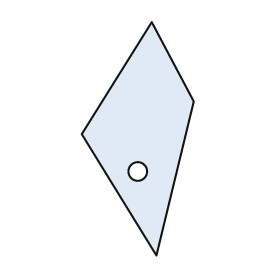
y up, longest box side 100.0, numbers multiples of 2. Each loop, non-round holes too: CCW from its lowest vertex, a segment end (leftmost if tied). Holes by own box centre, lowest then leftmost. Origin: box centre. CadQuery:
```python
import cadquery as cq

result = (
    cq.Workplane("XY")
    .moveTo(8.0, -50.0)
    .lineTo(24.0, 16.0)
    .lineTo(6.0, 50.0)
    .lineTo(-24.0, 2.0)
    .close()
    .moveTo(0.0, -14.0)
    .circle(4.0)
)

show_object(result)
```